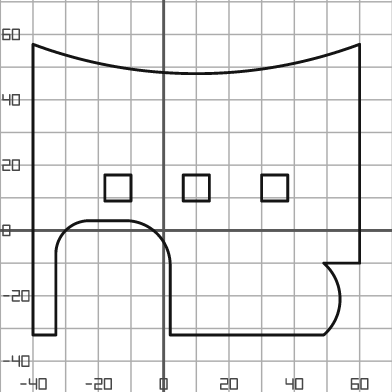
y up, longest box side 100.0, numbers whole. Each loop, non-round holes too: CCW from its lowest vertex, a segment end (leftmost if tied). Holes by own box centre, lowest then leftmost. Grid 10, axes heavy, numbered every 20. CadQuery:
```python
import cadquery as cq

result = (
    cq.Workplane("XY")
    .moveTo(-40.0, -32.0)
    .lineTo(-33.0, -32.0)
    .lineTo(-33.0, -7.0)
    .threePointArc((-30.0, 0.0), (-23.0, 3.0))
    .lineTo(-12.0, 3.0)
    .threePointArc((-2.0, -1.0), (2.0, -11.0))
    .lineTo(2.0, -32.0)
    .lineTo(49.0, -32.0)
    .threePointArc((54.0, -21.0), (49.0, -10.0))
    .lineTo(60.0, -10.0)
    .lineTo(60.0, 57.0)
    .threePointArc((10.0, 48.0), (-40.0, 57.0))
    .close()
    .moveTo(-18.0, 9.0)
    .lineTo(-10.0, 9.0)
    .lineTo(-10.0, 17.0)
    .lineTo(-18.0, 17.0)
    .close()
    .moveTo(6.0, 9.0)
    .lineTo(14.0, 9.0)
    .lineTo(14.0, 17.0)
    .lineTo(6.0, 17.0)
    .close()
    .moveTo(30.0, 9.0)
    .lineTo(38.0, 9.0)
    .lineTo(38.0, 17.0)
    .lineTo(30.0, 17.0)
    .close()
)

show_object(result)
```